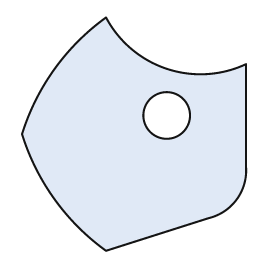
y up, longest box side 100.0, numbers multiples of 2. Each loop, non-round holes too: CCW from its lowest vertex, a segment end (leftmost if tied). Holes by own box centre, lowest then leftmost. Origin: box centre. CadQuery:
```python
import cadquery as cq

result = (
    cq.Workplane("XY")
    .moveTo(-12.0, -50.0)
    .lineTo(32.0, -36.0)
    .threePointArc((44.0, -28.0), (48.0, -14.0))
    .lineTo(48.0, 30.0)
    .threePointArc((14.0, 28.0), (-12.0, 50.0))
    .threePointArc((-34.0, 28.0), (-48.0, 0.0))
    .threePointArc((-34.0, -28.0), (-12.0, -50.0))
    .close()
    .moveTo(14.0, 8.0)
    .circle(10.0)
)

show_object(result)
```